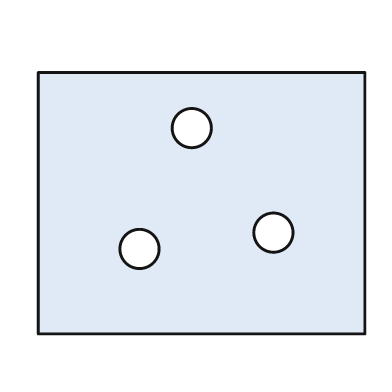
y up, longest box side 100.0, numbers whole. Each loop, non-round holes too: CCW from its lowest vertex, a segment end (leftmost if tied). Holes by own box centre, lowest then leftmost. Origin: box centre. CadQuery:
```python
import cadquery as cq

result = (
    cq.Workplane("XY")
    .moveTo(-50.0, -40.0)
    .lineTo(50.0, -40.0)
    .lineTo(50.0, 40.0)
    .lineTo(-50.0, 40.0)
    .close()
    .moveTo(-19.0, -14.0)
    .circle(6.0)
    .moveTo(22.0, -9.0)
    .circle(6.0)
    .moveTo(-3.0, 23.0)
    .circle(6.0)
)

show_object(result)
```